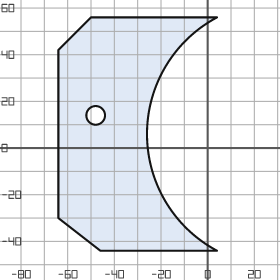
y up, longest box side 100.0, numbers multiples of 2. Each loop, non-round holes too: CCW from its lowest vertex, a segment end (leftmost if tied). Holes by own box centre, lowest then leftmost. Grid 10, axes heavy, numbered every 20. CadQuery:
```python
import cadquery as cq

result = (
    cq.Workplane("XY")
    .moveTo(-46.0, -44.0)
    .lineTo(4.0, -44.0)
    .threePointArc((-26.0, 6.0), (4.0, 56.0))
    .lineTo(-50.0, 56.0)
    .lineTo(-64.0, 42.0)
    .lineTo(-64.0, -30.0)
    .close()
    .moveTo(-48.0, 14.0)
    .circle(4.0)
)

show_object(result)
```